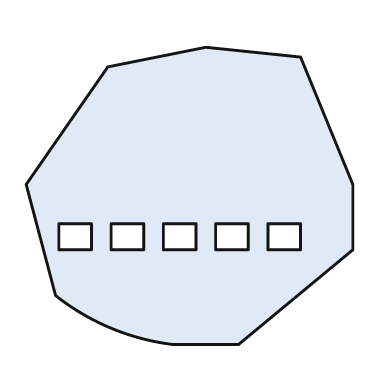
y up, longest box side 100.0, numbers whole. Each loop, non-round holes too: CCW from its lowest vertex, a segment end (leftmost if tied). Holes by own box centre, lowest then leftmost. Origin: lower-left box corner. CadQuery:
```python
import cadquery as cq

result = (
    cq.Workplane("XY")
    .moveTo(45.0, 0.0)
    .lineTo(65.0, 0.0)
    .lineTo(100.0, 29.0)
    .lineTo(100.0, 49.0)
    .lineTo(84.0, 88.0)
    .lineTo(55.0, 91.0)
    .lineTo(25.0, 85.0)
    .lineTo(0.0, 49.0)
    .lineTo(9.0, 15.0)
    .threePointArc((26.0, 5.0), (45.0, 0.0))
    .close()
    .moveTo(10.0, 29.0)
    .lineTo(20.0, 29.0)
    .lineTo(20.0, 37.0)
    .lineTo(10.0, 37.0)
    .close()
    .moveTo(26.0, 29.0)
    .lineTo(36.0, 29.0)
    .lineTo(36.0, 37.0)
    .lineTo(26.0, 37.0)
    .close()
    .moveTo(42.0, 29.0)
    .lineTo(52.0, 29.0)
    .lineTo(52.0, 37.0)
    .lineTo(42.0, 37.0)
    .close()
    .moveTo(58.0, 29.0)
    .lineTo(68.0, 29.0)
    .lineTo(68.0, 37.0)
    .lineTo(58.0, 37.0)
    .close()
    .moveTo(74.0, 29.0)
    .lineTo(84.0, 29.0)
    .lineTo(84.0, 37.0)
    .lineTo(74.0, 37.0)
    .close()
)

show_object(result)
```